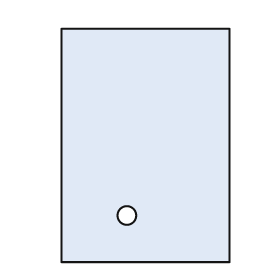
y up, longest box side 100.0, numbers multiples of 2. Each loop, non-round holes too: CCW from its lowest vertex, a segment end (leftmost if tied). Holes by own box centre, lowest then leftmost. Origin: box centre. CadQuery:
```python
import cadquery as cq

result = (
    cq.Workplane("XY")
    .moveTo(-36.0, -50.0)
    .lineTo(36.0, -50.0)
    .lineTo(36.0, 50.0)
    .lineTo(-36.0, 50.0)
    .close()
    .moveTo(-8.0, -30.0)
    .circle(4.0)
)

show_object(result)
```